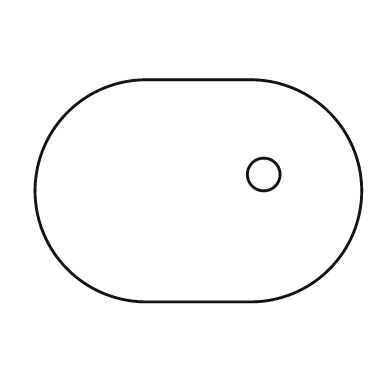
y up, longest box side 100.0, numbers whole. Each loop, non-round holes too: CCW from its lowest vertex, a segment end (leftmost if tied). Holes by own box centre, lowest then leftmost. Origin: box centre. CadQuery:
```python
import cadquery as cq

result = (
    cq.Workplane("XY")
    .moveTo(-16.0, -34.0)
    .lineTo(16.0, -34.0)
    .threePointArc((50.0, 0.0), (16.0, 34.0))
    .lineTo(-16.0, 34.0)
    .threePointArc((-50.0, 0.0), (-16.0, -34.0))
    .close()
    .moveTo(20.0, 5.0)
    .circle(5.0)
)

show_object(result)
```